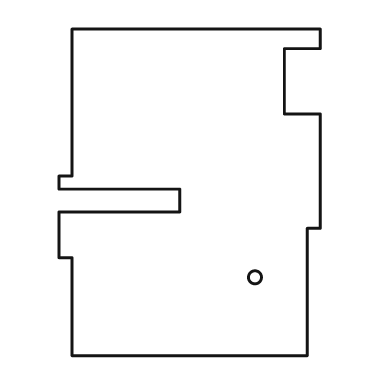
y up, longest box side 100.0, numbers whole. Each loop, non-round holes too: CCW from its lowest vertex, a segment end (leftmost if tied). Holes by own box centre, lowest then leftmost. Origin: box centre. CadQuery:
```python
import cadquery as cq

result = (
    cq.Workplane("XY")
    .moveTo(-36.0, -50.0)
    .lineTo(36.0, -50.0)
    .lineTo(36.0, -11.0)
    .lineTo(40.0, -11.0)
    .lineTo(40.0, 24.0)
    .lineTo(29.0, 24.0)
    .lineTo(29.0, 44.0)
    .lineTo(40.0, 44.0)
    .lineTo(40.0, 50.0)
    .lineTo(-36.0, 50.0)
    .lineTo(-36.0, 5.0)
    .lineTo(-40.0, 5.0)
    .lineTo(-40.0, 1.0)
    .lineTo(-3.0, 1.0)
    .lineTo(-3.0, -6.0)
    .lineTo(-40.0, -6.0)
    .lineTo(-40.0, -20.0)
    .lineTo(-36.0, -20.0)
    .close()
    .moveTo(20.0, -26.0)
    .circle(2.0)
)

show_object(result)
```